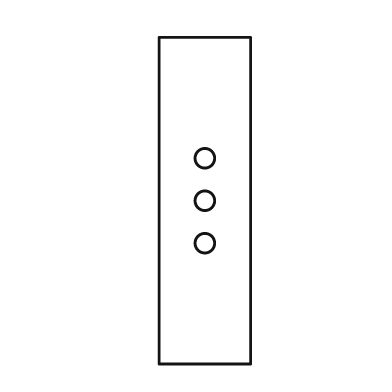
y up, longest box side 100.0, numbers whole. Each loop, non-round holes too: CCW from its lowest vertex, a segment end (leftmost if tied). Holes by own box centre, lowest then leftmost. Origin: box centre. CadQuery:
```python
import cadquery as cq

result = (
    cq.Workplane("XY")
    .moveTo(-14.0, -50.0)
    .lineTo(14.0, -50.0)
    .lineTo(14.0, 50.0)
    .lineTo(-14.0, 50.0)
    .close()
    .moveTo(0.0, -13.0)
    .circle(3.0)
    .moveTo(0.0, 0.0)
    .circle(3.0)
    .moveTo(0.0, 13.0)
    .circle(3.0)
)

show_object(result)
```